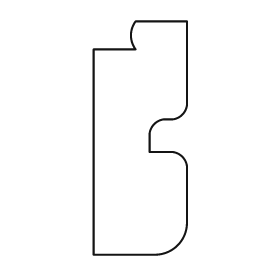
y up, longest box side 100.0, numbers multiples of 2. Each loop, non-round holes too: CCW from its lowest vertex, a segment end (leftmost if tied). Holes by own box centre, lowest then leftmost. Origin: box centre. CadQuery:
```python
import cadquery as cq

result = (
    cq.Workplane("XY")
    .moveTo(-20.0, -50.0)
    .lineTo(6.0, -50.0)
    .threePointArc((16.0, -46.0), (20.0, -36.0))
    .lineTo(20.0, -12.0)
    .threePointArc((18.0, -8.0), (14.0, -6.0))
    .lineTo(4.0, -6.0)
    .lineTo(4.0, 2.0)
    .threePointArc((6.0, 6.0), (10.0, 8.0))
    .lineTo(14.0, 8.0)
    .threePointArc((18.0, 10.0), (20.0, 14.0))
    .lineTo(20.0, 50.0)
    .lineTo(-2.0, 50.0)
    .threePointArc((-4.0, 44.0), (-2.0, 38.0))
    .lineTo(-20.0, 38.0)
    .close()
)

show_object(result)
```